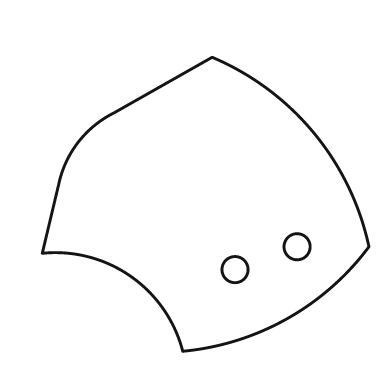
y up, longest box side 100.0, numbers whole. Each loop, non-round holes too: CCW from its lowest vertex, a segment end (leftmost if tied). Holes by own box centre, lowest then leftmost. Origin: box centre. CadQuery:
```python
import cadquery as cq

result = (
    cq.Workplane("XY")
    .moveTo(-7.0, -45.0)
    .threePointArc((25.0, -35.0), (50.0, -13.0))
    .threePointArc((33.0, 22.0), (2.0, 45.0))
    .lineTo(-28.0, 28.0)
    .threePointArc((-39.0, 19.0), (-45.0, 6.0))
    .lineTo(-50.0, -15.0)
    .threePointArc((-23.0, -22.0), (-7.0, -45.0))
    .close()
    .moveTo(9.0, -20.0)
    .circle(4.0)
    .moveTo(28.0, -13.0)
    .circle(4.0)
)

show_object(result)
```